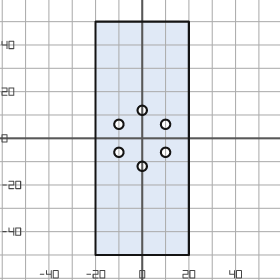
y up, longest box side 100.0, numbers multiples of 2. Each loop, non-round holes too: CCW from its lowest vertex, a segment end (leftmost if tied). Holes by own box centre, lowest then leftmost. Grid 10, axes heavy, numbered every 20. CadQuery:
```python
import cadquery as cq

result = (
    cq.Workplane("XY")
    .moveTo(-20.0, -50.0)
    .lineTo(20.0, -50.0)
    .lineTo(20.0, 50.0)
    .lineTo(-20.0, 50.0)
    .close()
    .moveTo(0.0, -12.0)
    .circle(2.0)
    .moveTo(-10.0, -6.0)
    .circle(2.0)
    .moveTo(10.0, -6.0)
    .circle(2.0)
    .moveTo(-10.0, 6.0)
    .circle(2.0)
    .moveTo(10.0, 6.0)
    .circle(2.0)
    .moveTo(0.0, 12.0)
    .circle(2.0)
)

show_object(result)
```